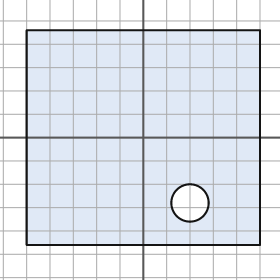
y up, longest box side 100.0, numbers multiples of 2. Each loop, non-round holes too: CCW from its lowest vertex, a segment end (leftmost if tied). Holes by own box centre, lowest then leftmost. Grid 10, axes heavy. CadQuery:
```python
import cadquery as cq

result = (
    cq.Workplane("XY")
    .moveTo(-50.0, -46.0)
    .lineTo(50.0, -46.0)
    .lineTo(50.0, 46.0)
    .lineTo(-50.0, 46.0)
    .close()
    .moveTo(20.0, -28.0)
    .circle(8.0)
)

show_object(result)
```